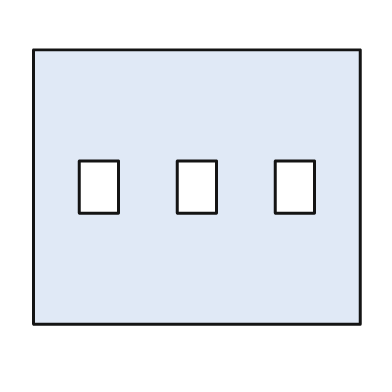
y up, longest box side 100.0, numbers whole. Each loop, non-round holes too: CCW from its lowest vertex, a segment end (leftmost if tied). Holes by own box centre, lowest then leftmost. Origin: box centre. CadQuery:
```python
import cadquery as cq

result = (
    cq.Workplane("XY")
    .moveTo(-50.0, -42.0)
    .lineTo(50.0, -42.0)
    .lineTo(50.0, 42.0)
    .lineTo(-50.0, 42.0)
    .close()
    .moveTo(-36.0, -8.0)
    .lineTo(-24.0, -8.0)
    .lineTo(-24.0, 8.0)
    .lineTo(-36.0, 8.0)
    .close()
    .moveTo(-6.0, -8.0)
    .lineTo(6.0, -8.0)
    .lineTo(6.0, 8.0)
    .lineTo(-6.0, 8.0)
    .close()
    .moveTo(24.0, -8.0)
    .lineTo(36.0, -8.0)
    .lineTo(36.0, 8.0)
    .lineTo(24.0, 8.0)
    .close()
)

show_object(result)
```